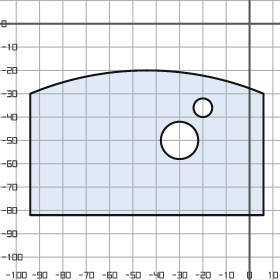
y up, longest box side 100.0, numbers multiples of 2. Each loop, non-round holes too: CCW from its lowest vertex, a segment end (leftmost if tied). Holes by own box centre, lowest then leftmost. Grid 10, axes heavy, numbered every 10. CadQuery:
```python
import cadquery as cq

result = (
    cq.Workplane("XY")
    .moveTo(-94.0, -82.0)
    .lineTo(6.0, -82.0)
    .lineTo(6.0, -30.0)
    .threePointArc((-44.0, -20.0), (-94.0, -30.0))
    .close()
    .moveTo(-30.0, -50.0)
    .circle(8.0)
    .moveTo(-20.0, -36.0)
    .circle(4.0)
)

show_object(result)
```